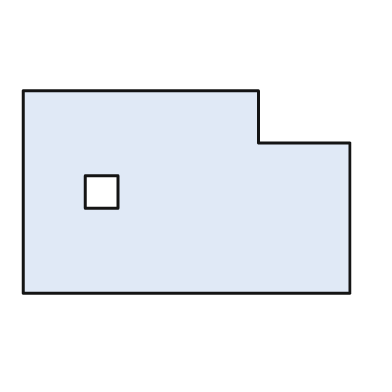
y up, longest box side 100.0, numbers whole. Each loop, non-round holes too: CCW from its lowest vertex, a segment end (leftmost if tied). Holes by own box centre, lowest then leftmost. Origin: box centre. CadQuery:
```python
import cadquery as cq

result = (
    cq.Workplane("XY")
    .moveTo(-50.0, -31.0)
    .lineTo(50.0, -31.0)
    .lineTo(50.0, 15.0)
    .lineTo(22.0, 15.0)
    .lineTo(22.0, 31.0)
    .lineTo(-50.0, 31.0)
    .close()
    .moveTo(-31.0, -5.0)
    .lineTo(-21.0, -5.0)
    .lineTo(-21.0, 5.0)
    .lineTo(-31.0, 5.0)
    .close()
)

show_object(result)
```